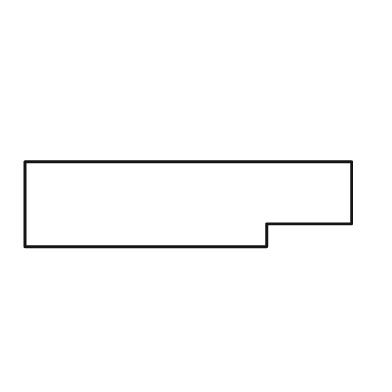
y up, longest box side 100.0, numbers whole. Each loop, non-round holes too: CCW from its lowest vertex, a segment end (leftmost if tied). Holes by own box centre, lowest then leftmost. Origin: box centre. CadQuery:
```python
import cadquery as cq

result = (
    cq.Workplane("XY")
    .moveTo(-50.0, -13.0)
    .lineTo(24.0, -13.0)
    .lineTo(24.0, -6.0)
    .lineTo(50.0, -6.0)
    .lineTo(50.0, 13.0)
    .lineTo(-50.0, 13.0)
    .close()
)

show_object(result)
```